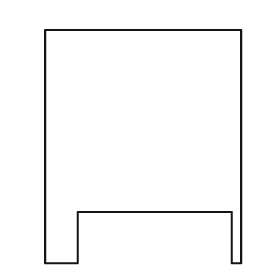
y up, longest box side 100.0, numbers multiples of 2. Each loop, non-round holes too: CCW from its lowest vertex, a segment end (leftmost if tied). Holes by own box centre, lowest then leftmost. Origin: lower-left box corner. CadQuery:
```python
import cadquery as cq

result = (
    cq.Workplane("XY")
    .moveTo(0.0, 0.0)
    .lineTo(14.0, 0.0)
    .lineTo(14.0, 22.0)
    .lineTo(80.0, 22.0)
    .lineTo(80.0, 0.0)
    .lineTo(84.0, 0.0)
    .lineTo(84.0, 100.0)
    .lineTo(0.0, 100.0)
    .close()
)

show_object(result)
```